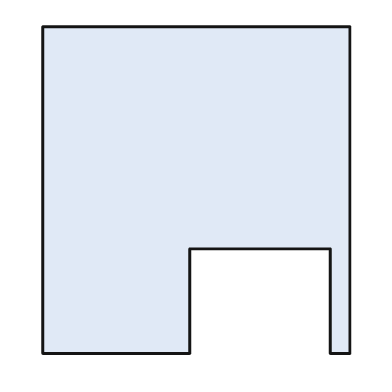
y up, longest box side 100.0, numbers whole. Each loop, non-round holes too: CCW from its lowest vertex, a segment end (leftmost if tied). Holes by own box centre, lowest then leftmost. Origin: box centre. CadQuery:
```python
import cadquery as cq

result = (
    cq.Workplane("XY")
    .moveTo(-47.0, -50.0)
    .lineTo(-2.0, -50.0)
    .lineTo(-2.0, -18.0)
    .lineTo(41.0, -18.0)
    .lineTo(41.0, -50.0)
    .lineTo(47.0, -50.0)
    .lineTo(47.0, 50.0)
    .lineTo(-47.0, 50.0)
    .close()
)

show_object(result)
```